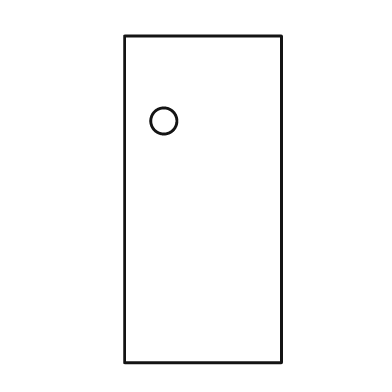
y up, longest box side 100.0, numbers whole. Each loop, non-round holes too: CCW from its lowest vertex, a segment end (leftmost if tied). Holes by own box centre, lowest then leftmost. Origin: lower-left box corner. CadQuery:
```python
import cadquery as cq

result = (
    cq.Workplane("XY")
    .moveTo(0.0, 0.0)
    .lineTo(48.0, 0.0)
    .lineTo(48.0, 100.0)
    .lineTo(0.0, 100.0)
    .close()
    .moveTo(12.0, 74.0)
    .circle(4.0)
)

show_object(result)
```